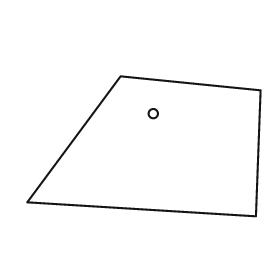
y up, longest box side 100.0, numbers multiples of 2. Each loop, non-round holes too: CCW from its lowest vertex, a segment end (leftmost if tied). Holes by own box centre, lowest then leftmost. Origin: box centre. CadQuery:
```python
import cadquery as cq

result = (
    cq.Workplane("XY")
    .moveTo(48.0, -30.0)
    .lineTo(50.0, 24.0)
    .lineTo(-10.0, 30.0)
    .lineTo(-50.0, -24.0)
    .close()
    .moveTo(4.0, 14.0)
    .circle(2.0)
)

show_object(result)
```